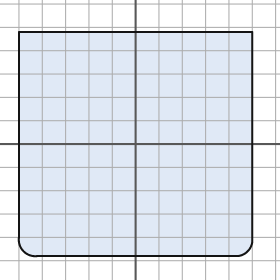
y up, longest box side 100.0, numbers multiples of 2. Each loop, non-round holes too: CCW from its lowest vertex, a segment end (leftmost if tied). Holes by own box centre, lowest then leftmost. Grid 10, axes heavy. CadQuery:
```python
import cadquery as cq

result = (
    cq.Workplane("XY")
    .moveTo(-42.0, -48.0)
    .lineTo(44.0, -48.0)
    .threePointArc((48.0, -46.0), (50.0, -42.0))
    .lineTo(50.0, 48.0)
    .lineTo(-50.0, 48.0)
    .lineTo(-50.0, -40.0)
    .threePointArc((-48.0, -46.0), (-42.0, -48.0))
    .close()
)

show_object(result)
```